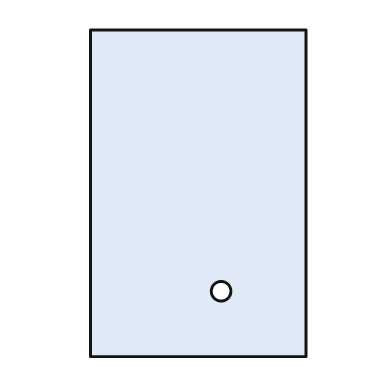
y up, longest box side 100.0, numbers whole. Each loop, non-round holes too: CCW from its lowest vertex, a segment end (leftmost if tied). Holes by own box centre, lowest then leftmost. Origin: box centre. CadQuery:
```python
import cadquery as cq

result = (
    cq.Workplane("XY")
    .moveTo(-33.0, -50.0)
    .lineTo(33.0, -50.0)
    .lineTo(33.0, 50.0)
    .lineTo(-33.0, 50.0)
    .close()
    .moveTo(7.0, -30.0)
    .circle(3.0)
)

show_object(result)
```